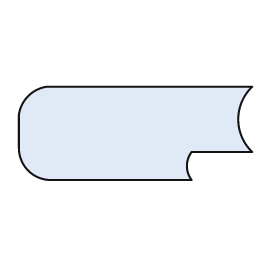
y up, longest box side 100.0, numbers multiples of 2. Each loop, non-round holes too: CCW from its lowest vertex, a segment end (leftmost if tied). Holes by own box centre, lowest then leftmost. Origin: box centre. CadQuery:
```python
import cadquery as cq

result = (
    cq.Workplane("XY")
    .moveTo(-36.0, -20.0)
    .lineTo(24.0, -20.0)
    .threePointArc((22.0, -14.0), (24.0, -8.0))
    .lineTo(50.0, -8.0)
    .threePointArc((44.0, 6.0), (50.0, 20.0))
    .lineTo(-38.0, 20.0)
    .threePointArc((-46.0, 16.0), (-50.0, 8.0))
    .lineTo(-50.0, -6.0)
    .threePointArc((-46.0, -16.0), (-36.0, -20.0))
    .close()
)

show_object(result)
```